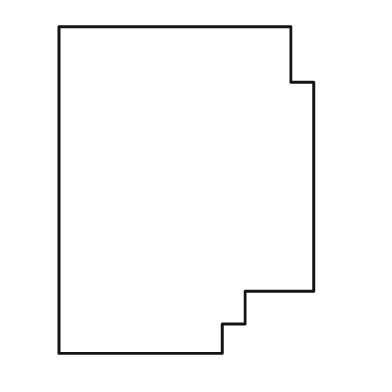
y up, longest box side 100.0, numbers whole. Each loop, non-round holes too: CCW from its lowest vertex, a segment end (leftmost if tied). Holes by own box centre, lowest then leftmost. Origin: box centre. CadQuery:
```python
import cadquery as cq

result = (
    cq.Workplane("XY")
    .moveTo(-39.0, -50.0)
    .lineTo(11.0, -50.0)
    .lineTo(11.0, -41.0)
    .lineTo(18.0, -41.0)
    .lineTo(18.0, -31.0)
    .lineTo(39.0, -31.0)
    .lineTo(39.0, 33.0)
    .lineTo(32.0, 33.0)
    .lineTo(32.0, 50.0)
    .lineTo(-39.0, 50.0)
    .close()
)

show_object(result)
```